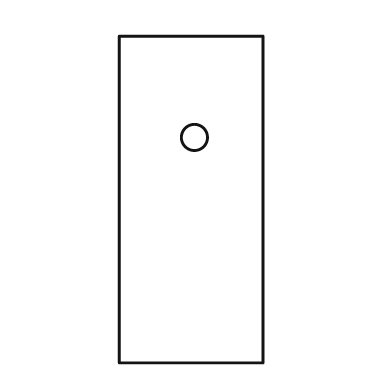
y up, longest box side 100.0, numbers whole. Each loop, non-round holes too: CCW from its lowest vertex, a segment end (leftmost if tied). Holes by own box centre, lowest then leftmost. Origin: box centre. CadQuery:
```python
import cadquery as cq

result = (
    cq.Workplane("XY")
    .moveTo(-22.0, -50.0)
    .lineTo(22.0, -50.0)
    .lineTo(22.0, 50.0)
    .lineTo(-22.0, 50.0)
    .close()
    .moveTo(1.0, 19.0)
    .circle(4.0)
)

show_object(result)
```